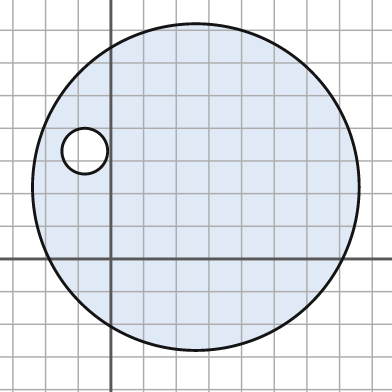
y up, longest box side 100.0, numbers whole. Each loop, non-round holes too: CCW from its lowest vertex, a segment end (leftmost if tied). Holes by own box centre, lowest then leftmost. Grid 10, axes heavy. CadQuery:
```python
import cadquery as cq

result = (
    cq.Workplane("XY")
    .moveTo(26.0, 22.0)
    .circle(50.0)
    .moveTo(-8.0, 33.0)
    .circle(7.0)
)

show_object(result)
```